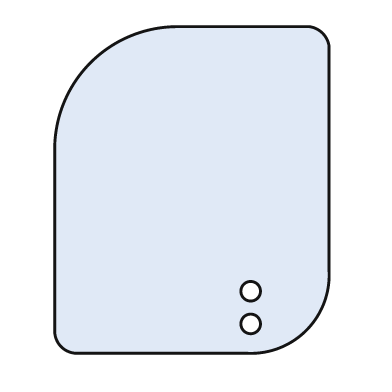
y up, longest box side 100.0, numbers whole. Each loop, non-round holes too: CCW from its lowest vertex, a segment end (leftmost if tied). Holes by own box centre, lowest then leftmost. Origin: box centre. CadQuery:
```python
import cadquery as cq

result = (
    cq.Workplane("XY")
    .moveTo(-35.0, -50.0)
    .lineTo(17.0, -50.0)
    .threePointArc((35.0, -43.0), (42.0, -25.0))
    .lineTo(42.0, 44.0)
    .threePointArc((40.0, 48.0), (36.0, 50.0))
    .lineTo(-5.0, 50.0)
    .threePointArc((-31.0, 39.0), (-42.0, 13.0))
    .lineTo(-42.0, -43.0)
    .threePointArc((-40.0, -48.0), (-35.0, -50.0))
    .close()
    .moveTo(18.0, -41.0)
    .circle(3.0)
    .moveTo(18.0, -31.0)
    .circle(3.0)
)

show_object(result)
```